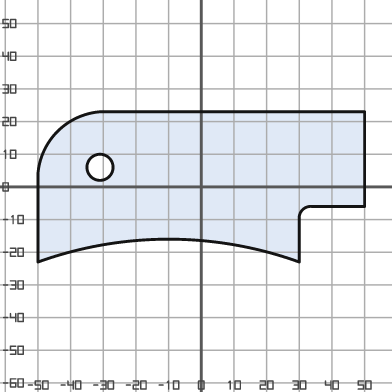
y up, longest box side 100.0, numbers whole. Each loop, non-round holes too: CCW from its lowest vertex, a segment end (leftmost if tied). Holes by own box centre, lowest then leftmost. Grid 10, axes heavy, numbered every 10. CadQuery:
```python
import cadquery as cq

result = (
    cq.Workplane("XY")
    .moveTo(-50.0, -23.0)
    .threePointArc((-10.0, -16.0), (30.0, -23.0))
    .lineTo(30.0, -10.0)
    .threePointArc((31.0, -7.0), (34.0, -6.0))
    .lineTo(50.0, -6.0)
    .lineTo(50.0, 23.0)
    .lineTo(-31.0, 23.0)
    .threePointArc((-44.0, 17.0), (-50.0, 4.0))
    .close()
    .moveTo(-31.0, 6.0)
    .circle(4.0)
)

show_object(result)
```